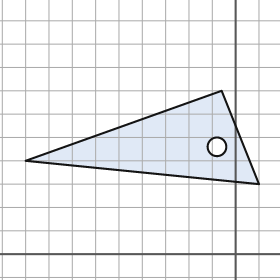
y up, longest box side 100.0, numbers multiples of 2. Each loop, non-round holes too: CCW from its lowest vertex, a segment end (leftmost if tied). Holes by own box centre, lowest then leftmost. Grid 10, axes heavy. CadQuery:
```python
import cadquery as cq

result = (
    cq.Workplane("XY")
    .moveTo(10.0, 30.0)
    .lineTo(-6.0, 70.0)
    .lineTo(-90.0, 40.0)
    .close()
    .moveTo(-8.0, 46.0)
    .circle(4.0)
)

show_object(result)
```